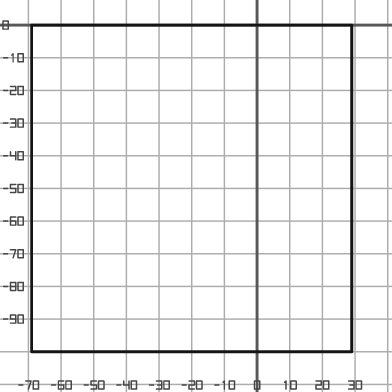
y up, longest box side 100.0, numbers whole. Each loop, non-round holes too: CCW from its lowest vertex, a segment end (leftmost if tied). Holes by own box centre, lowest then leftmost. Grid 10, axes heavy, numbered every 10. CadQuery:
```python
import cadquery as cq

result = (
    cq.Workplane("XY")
    .moveTo(-69.0, -100.0)
    .lineTo(29.0, -100.0)
    .lineTo(29.0, 0.0)
    .lineTo(-69.0, 0.0)
    .close()
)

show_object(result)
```